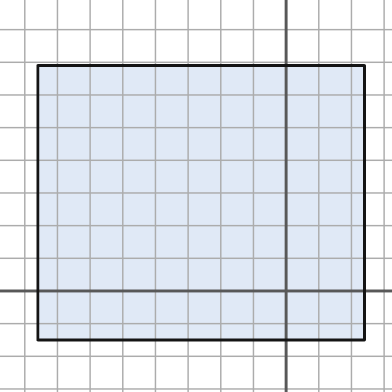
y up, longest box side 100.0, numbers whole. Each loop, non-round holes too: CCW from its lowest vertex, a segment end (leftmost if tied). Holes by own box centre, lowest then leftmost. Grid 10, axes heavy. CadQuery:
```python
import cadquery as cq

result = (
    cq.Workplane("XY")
    .moveTo(-76.0, -15.0)
    .lineTo(24.0, -15.0)
    .lineTo(24.0, 69.0)
    .lineTo(-76.0, 69.0)
    .close()
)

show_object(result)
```